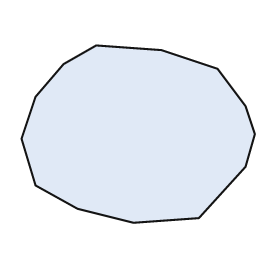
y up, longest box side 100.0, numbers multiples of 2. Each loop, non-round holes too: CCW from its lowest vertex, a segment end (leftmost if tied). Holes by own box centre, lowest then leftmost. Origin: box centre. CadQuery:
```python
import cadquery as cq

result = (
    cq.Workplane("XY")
    .moveTo(-2.0, -38.0)
    .lineTo(26.0, -36.0)
    .lineTo(46.0, -14.0)
    .lineTo(50.0, 0.0)
    .lineTo(46.0, 12.0)
    .lineTo(34.0, 28.0)
    .lineTo(10.0, 36.0)
    .lineTo(-18.0, 38.0)
    .lineTo(-32.0, 30.0)
    .lineTo(-44.0, 16.0)
    .lineTo(-50.0, -2.0)
    .lineTo(-44.0, -22.0)
    .lineTo(-26.0, -32.0)
    .close()
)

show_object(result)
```